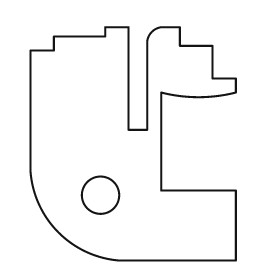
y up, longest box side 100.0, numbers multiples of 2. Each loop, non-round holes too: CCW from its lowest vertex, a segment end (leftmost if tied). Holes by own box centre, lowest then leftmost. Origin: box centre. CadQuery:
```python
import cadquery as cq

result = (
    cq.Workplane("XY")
    .moveTo(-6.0, -50.0)
    .lineTo(44.0, -50.0)
    .lineTo(44.0, -20.0)
    .lineTo(12.0, -20.0)
    .lineTo(12.0, 22.0)
    .threePointArc((28.0, 20.0), (44.0, 22.0))
    .lineTo(44.0, 28.0)
    .lineTo(34.0, 28.0)
    .lineTo(34.0, 42.0)
    .lineTo(20.0, 42.0)
    .lineTo(20.0, 50.0)
    .lineTo(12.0, 50.0)
    .threePointArc((8.0, 48.0), (6.0, 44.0))
    .lineTo(6.0, 6.0)
    .lineTo(-2.0, 6.0)
    .lineTo(-2.0, 50.0)
    .lineTo(-12.0, 50.0)
    .lineTo(-12.0, 46.0)
    .lineTo(-34.0, 46.0)
    .lineTo(-34.0, 40.0)
    .lineTo(-44.0, 40.0)
    .lineTo(-44.0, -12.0)
    .threePointArc((-32.0, -38.0), (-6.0, -50.0))
    .close()
    .moveTo(-14.0, -22.0)
    .circle(8.0)
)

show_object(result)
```